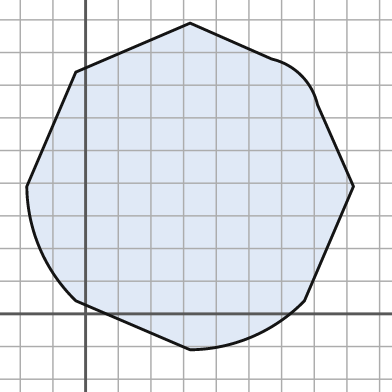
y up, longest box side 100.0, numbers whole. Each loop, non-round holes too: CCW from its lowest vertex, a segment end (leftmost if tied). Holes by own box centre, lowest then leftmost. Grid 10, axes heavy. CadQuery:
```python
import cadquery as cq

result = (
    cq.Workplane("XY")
    .moveTo(32.0, -11.0)
    .threePointArc((51.0, -7.0), (67.0, 4.0))
    .lineTo(82.0, 39.0)
    .lineTo(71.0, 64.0)
    .threePointArc((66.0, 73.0), (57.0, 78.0))
    .lineTo(32.0, 89.0)
    .lineTo(-3.0, 74.0)
    .lineTo(-18.0, 39.0)
    .threePointArc((-14.0, 20.0), (-3.0, 4.0))
    .close()
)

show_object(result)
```